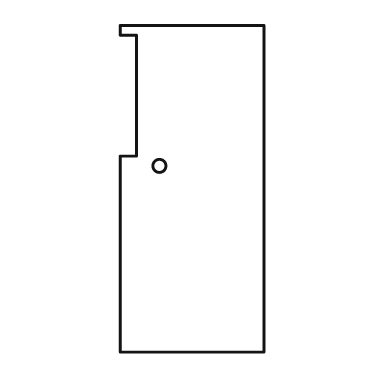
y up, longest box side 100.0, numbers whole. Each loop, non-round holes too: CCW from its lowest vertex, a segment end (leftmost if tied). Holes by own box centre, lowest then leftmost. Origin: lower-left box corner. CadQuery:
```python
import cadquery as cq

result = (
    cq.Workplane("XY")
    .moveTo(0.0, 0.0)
    .lineTo(44.0, 0.0)
    .lineTo(44.0, 100.0)
    .lineTo(0.0, 100.0)
    .lineTo(0.0, 97.0)
    .lineTo(5.0, 97.0)
    .lineTo(5.0, 60.0)
    .lineTo(0.0, 60.0)
    .close()
    .moveTo(12.0, 57.0)
    .circle(2.0)
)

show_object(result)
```